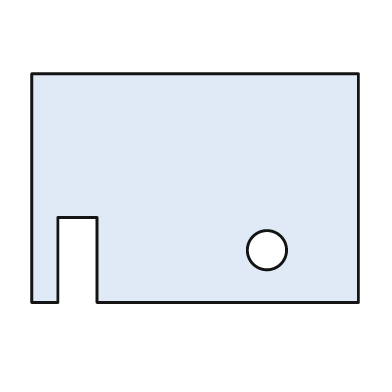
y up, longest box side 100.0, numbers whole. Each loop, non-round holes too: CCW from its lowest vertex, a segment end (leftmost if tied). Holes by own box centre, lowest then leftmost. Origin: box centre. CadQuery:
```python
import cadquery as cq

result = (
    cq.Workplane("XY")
    .moveTo(-50.0, -35.0)
    .lineTo(-42.0, -35.0)
    .lineTo(-42.0, -9.0)
    .lineTo(-30.0, -9.0)
    .lineTo(-30.0, -35.0)
    .lineTo(50.0, -35.0)
    .lineTo(50.0, 35.0)
    .lineTo(-50.0, 35.0)
    .close()
    .moveTo(22.0, -19.0)
    .circle(6.0)
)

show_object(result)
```